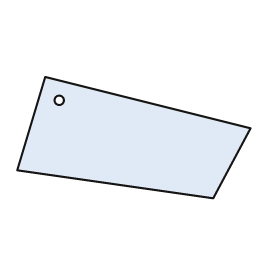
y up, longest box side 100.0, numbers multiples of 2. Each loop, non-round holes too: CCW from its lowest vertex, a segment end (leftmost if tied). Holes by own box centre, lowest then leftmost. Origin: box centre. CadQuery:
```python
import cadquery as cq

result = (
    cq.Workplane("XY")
    .moveTo(34.0, -26.0)
    .lineTo(50.0, 4.0)
    .lineTo(-38.0, 26.0)
    .lineTo(-50.0, -14.0)
    .close()
    .moveTo(-32.0, 16.0)
    .circle(2.0)
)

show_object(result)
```